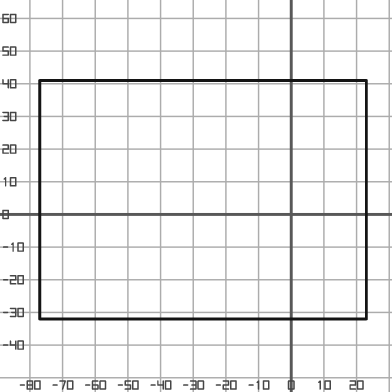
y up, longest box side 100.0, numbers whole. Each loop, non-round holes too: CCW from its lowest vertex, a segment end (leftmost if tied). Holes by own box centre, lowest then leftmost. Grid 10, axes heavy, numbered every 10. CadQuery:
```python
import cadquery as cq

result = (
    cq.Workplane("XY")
    .moveTo(-77.0, -32.0)
    .lineTo(23.0, -32.0)
    .lineTo(23.0, 41.0)
    .lineTo(-77.0, 41.0)
    .close()
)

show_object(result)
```